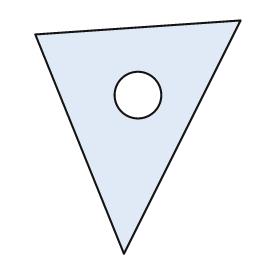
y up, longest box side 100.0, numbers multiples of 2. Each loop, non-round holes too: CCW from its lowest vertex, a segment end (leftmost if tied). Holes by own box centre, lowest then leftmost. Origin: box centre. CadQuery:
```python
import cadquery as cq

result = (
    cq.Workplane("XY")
    .moveTo(-6.0, -50.0)
    .lineTo(44.0, 50.0)
    .lineTo(-44.0, 44.0)
    .close()
    .moveTo(0.0, 18.0)
    .circle(10.0)
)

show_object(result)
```